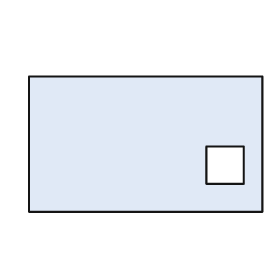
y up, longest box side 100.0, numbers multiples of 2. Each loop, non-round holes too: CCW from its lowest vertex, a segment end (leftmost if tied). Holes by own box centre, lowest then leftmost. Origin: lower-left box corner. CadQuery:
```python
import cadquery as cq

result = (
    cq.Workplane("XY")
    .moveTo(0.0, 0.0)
    .lineTo(100.0, 0.0)
    .lineTo(100.0, 58.0)
    .lineTo(0.0, 58.0)
    .close()
    .moveTo(76.0, 12.0)
    .lineTo(92.0, 12.0)
    .lineTo(92.0, 28.0)
    .lineTo(76.0, 28.0)
    .close()
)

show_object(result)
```